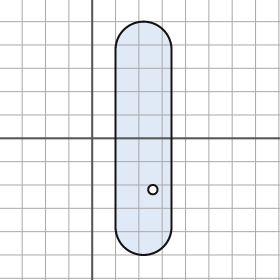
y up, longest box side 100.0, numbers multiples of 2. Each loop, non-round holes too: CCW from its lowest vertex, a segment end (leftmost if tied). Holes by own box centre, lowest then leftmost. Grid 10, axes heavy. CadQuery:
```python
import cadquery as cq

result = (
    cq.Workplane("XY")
    .moveTo(10.0, -38.0)
    .threePointArc((22.0, -50.0), (34.0, -38.0))
    .lineTo(34.0, 38.0)
    .threePointArc((22.0, 50.0), (10.0, 38.0))
    .close()
    .moveTo(26.0, -22.0)
    .circle(2.0)
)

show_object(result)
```